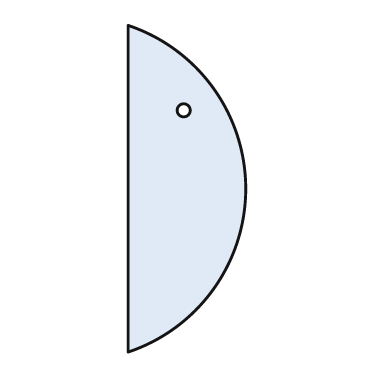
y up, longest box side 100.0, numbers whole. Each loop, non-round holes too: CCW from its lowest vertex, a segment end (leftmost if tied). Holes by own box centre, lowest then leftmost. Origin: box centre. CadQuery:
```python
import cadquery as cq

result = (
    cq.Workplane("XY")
    .moveTo(-18.0, -50.0)
    .threePointArc((18.0, 0.0), (-18.0, 50.0))
    .close()
    .moveTo(-1.0, 24.0)
    .circle(2.0)
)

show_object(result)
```